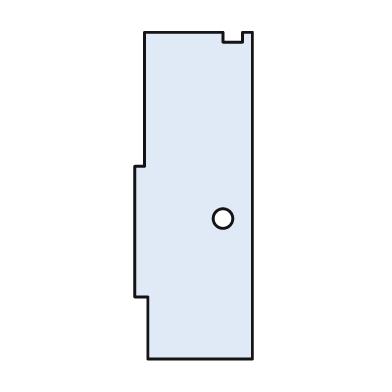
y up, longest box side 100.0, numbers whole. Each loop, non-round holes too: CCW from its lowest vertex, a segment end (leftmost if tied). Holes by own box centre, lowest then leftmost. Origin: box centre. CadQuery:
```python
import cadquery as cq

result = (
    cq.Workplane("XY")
    .moveTo(-14.0, -50.0)
    .lineTo(18.0, -50.0)
    .lineTo(18.0, 50.0)
    .lineTo(15.0, 50.0)
    .lineTo(15.0, 47.0)
    .lineTo(9.0, 47.0)
    .lineTo(9.0, 50.0)
    .lineTo(-15.0, 50.0)
    .lineTo(-15.0, 9.0)
    .lineTo(-18.0, 9.0)
    .lineTo(-18.0, -31.0)
    .lineTo(-14.0, -31.0)
    .close()
    .moveTo(9.0, -7.0)
    .circle(3.0)
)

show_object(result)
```